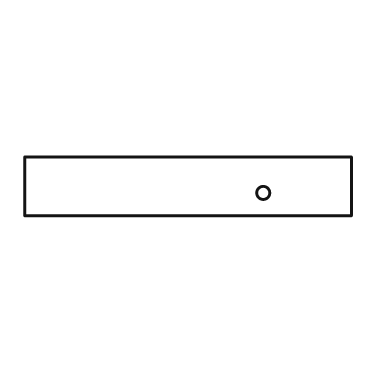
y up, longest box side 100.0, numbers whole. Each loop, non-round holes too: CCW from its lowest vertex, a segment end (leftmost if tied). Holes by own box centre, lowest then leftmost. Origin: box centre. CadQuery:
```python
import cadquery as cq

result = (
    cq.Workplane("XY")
    .moveTo(-50.0, -9.0)
    .lineTo(50.0, -9.0)
    .lineTo(50.0, 9.0)
    .lineTo(-50.0, 9.0)
    .close()
    .moveTo(23.0, -2.0)
    .circle(2.0)
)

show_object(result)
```